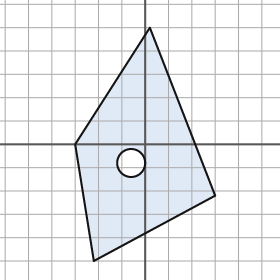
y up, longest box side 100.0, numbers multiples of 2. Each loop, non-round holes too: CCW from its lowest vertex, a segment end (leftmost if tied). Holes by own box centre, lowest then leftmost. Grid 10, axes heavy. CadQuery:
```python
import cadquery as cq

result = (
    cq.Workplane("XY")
    .moveTo(-22.0, -50.0)
    .lineTo(30.0, -22.0)
    .lineTo(2.0, 50.0)
    .lineTo(-30.0, 0.0)
    .close()
    .moveTo(-6.0, -8.0)
    .circle(6.0)
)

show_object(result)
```